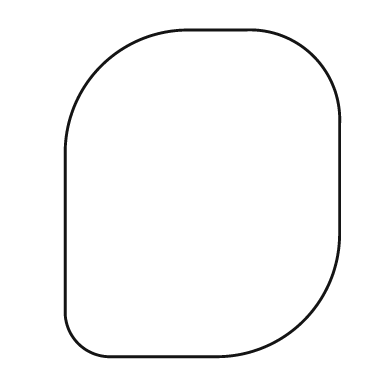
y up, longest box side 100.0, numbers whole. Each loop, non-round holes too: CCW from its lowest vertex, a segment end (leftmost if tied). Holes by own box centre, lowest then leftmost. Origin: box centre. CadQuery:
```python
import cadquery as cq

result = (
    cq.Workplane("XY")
    .moveTo(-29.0, -50.0)
    .lineTo(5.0, -50.0)
    .threePointArc((31.0, -39.0), (42.0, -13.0))
    .lineTo(42.0, 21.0)
    .threePointArc((34.0, 42.0), (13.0, 50.0))
    .lineTo(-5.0, 50.0)
    .threePointArc((-31.0, 39.0), (-42.0, 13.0))
    .lineTo(-42.0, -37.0)
    .threePointArc((-38.0, -46.0), (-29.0, -50.0))
    .close()
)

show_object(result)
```